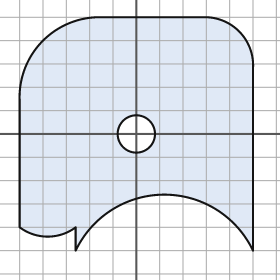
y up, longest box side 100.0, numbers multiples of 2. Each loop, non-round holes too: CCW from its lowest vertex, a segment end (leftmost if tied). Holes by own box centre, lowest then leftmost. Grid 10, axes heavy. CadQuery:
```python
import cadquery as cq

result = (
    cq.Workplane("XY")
    .moveTo(-26.0, -50.0)
    .threePointArc((12.0, -26.0), (50.0, -50.0))
    .lineTo(50.0, 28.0)
    .threePointArc((44.0, 44.0), (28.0, 50.0))
    .lineTo(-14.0, 50.0)
    .threePointArc((-40.0, 40.0), (-50.0, 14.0))
    .lineTo(-50.0, -40.0)
    .threePointArc((-38.0, -44.0), (-26.0, -40.0))
    .close()
    .moveTo(0.0, 0.0)
    .circle(8.0)
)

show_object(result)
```